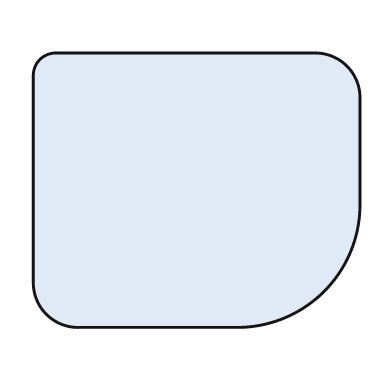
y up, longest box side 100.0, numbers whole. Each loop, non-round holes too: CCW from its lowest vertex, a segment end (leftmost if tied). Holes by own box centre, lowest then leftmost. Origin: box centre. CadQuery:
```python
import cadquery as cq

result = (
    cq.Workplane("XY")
    .moveTo(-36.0, -42.0)
    .lineTo(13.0, -42.0)
    .threePointArc((39.0, -31.0), (50.0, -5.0))
    .lineTo(50.0, 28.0)
    .threePointArc((46.0, 38.0), (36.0, 42.0))
    .lineTo(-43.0, 42.0)
    .threePointArc((-48.0, 40.0), (-50.0, 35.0))
    .lineTo(-50.0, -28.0)
    .threePointArc((-46.0, -38.0), (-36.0, -42.0))
    .close()
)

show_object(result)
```